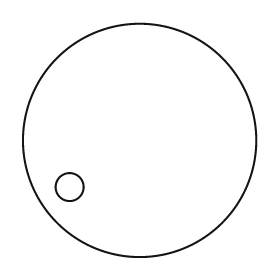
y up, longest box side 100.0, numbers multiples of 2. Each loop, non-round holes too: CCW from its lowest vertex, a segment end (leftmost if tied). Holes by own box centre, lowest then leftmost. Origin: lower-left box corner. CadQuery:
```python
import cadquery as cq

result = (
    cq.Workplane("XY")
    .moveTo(50.0, 50.0)
    .circle(50.0)
    .moveTo(20.0, 30.0)
    .circle(6.0)
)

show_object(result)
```